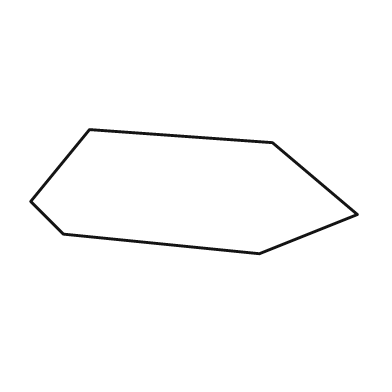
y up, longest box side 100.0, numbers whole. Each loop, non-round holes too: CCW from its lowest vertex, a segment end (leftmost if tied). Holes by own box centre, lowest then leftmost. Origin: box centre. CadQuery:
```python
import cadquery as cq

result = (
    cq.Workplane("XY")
    .moveTo(20.0, -19.0)
    .lineTo(50.0, -7.0)
    .lineTo(24.0, 15.0)
    .lineTo(-32.0, 19.0)
    .lineTo(-50.0, -3.0)
    .lineTo(-40.0, -13.0)
    .close()
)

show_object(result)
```